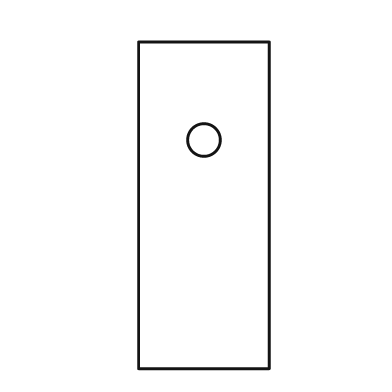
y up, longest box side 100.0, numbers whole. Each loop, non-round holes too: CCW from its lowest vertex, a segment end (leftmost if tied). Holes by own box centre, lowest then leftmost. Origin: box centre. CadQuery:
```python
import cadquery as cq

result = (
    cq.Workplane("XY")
    .moveTo(-20.0, -50.0)
    .lineTo(20.0, -50.0)
    .lineTo(20.0, 50.0)
    .lineTo(-20.0, 50.0)
    .close()
    .moveTo(0.0, 20.0)
    .circle(5.0)
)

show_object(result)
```